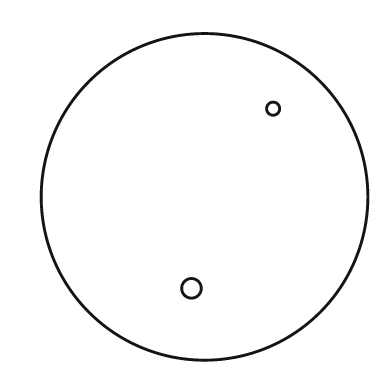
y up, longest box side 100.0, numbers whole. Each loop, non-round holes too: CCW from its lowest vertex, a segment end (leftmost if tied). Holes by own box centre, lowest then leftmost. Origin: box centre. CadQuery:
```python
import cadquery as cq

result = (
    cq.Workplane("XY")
    .moveTo(0.0, 0.0)
    .circle(50.0)
    .moveTo(-4.0, -28.0)
    .circle(3.0)
    .moveTo(21.0, 27.0)
    .circle(2.0)
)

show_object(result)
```